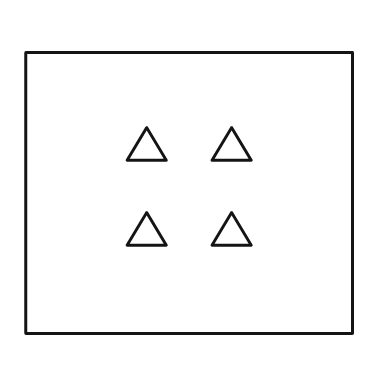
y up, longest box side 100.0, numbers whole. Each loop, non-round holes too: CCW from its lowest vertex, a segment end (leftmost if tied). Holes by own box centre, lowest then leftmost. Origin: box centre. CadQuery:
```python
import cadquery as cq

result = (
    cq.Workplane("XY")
    .moveTo(-50.0, -43.0)
    .lineTo(50.0, -43.0)
    .lineTo(50.0, 43.0)
    .lineTo(-50.0, 43.0)
    .close()
    .moveTo(-19.0, -16.0)
    .lineTo(-7.0, -16.0)
    .lineTo(-13.0, -6.0)
    .close()
    .moveTo(7.0, -16.0)
    .lineTo(19.0, -16.0)
    .lineTo(13.0, -6.0)
    .close()
    .moveTo(-19.0, 10.0)
    .lineTo(-7.0, 10.0)
    .lineTo(-13.0, 20.0)
    .close()
    .moveTo(7.0, 10.0)
    .lineTo(19.0, 10.0)
    .lineTo(13.0, 20.0)
    .close()
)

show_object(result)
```